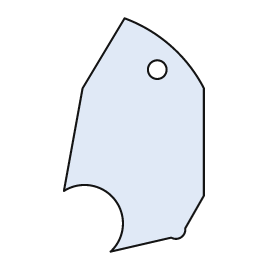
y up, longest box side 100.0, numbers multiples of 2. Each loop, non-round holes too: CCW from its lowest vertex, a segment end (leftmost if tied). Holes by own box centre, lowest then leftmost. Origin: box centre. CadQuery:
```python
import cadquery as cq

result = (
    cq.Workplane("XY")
    .moveTo(-10.0, -50.0)
    .lineTo(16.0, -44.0)
    .threePointArc((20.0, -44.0), (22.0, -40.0))
    .lineTo(30.0, -26.0)
    .lineTo(30.0, 20.0)
    .threePointArc((16.0, 38.0), (-4.0, 50.0))
    .lineTo(-22.0, 20.0)
    .lineTo(-30.0, -24.0)
    .threePointArc((-8.0, -28.0), (-10.0, -50.0))
    .close()
    .moveTo(10.0, 28.0)
    .circle(4.0)
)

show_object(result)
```